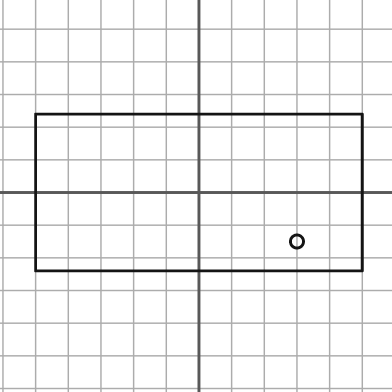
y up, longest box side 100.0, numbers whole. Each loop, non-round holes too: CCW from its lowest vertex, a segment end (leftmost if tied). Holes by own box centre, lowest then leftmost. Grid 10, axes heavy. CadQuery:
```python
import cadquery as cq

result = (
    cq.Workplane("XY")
    .moveTo(-50.0, -24.0)
    .lineTo(50.0, -24.0)
    .lineTo(50.0, 24.0)
    .lineTo(-50.0, 24.0)
    .close()
    .moveTo(30.0, -15.0)
    .circle(2.0)
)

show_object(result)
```